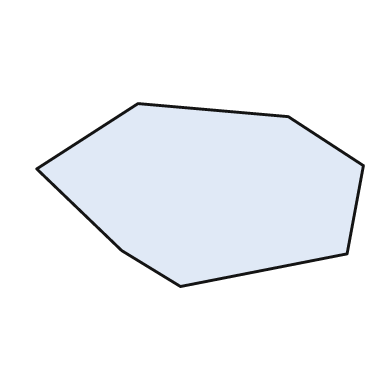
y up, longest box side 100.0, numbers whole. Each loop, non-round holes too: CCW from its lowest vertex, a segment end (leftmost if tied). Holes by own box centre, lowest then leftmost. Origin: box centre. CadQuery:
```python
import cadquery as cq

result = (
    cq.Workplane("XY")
    .moveTo(-6.0, -28.0)
    .lineTo(45.0, -18.0)
    .lineTo(50.0, 9.0)
    .lineTo(27.0, 24.0)
    .lineTo(-19.0, 28.0)
    .lineTo(-50.0, 8.0)
    .lineTo(-24.0, -17.0)
    .close()
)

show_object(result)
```